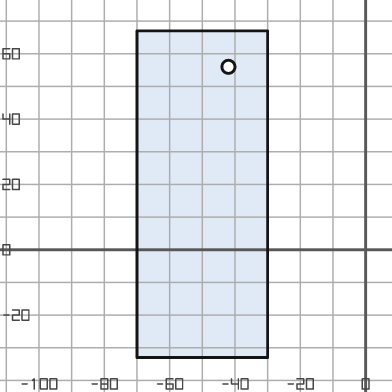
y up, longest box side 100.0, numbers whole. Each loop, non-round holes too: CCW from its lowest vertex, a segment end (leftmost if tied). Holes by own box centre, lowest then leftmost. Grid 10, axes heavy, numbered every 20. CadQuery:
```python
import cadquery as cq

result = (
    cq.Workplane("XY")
    .moveTo(-70.0, -33.0)
    .lineTo(-30.0, -33.0)
    .lineTo(-30.0, 67.0)
    .lineTo(-70.0, 67.0)
    .close()
    .moveTo(-42.0, 56.0)
    .circle(2.0)
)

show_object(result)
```